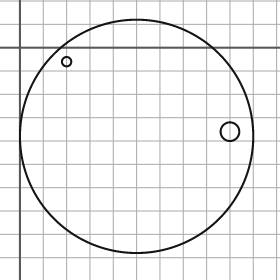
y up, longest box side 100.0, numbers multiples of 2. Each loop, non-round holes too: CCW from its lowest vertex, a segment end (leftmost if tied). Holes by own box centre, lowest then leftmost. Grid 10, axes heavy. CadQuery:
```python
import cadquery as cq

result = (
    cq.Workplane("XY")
    .moveTo(50.0, -38.0)
    .circle(50.0)
    .moveTo(90.0, -36.0)
    .circle(4.0)
    .moveTo(20.0, -6.0)
    .circle(2.0)
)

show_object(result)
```